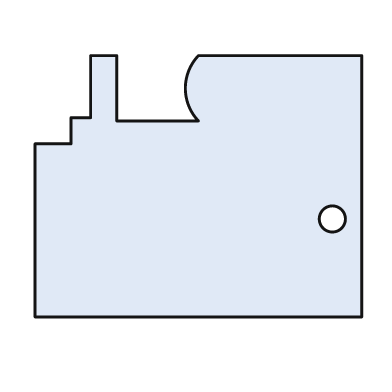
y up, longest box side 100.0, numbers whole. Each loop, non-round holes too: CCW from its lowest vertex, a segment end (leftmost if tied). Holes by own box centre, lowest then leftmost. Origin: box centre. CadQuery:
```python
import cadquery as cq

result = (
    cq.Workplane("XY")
    .moveTo(-50.0, -40.0)
    .lineTo(50.0, -40.0)
    .lineTo(50.0, 40.0)
    .lineTo(0.0, 40.0)
    .threePointArc((-4.0, 30.0), (0.0, 20.0))
    .lineTo(-25.0, 20.0)
    .lineTo(-25.0, 40.0)
    .lineTo(-33.0, 40.0)
    .lineTo(-33.0, 21.0)
    .lineTo(-39.0, 21.0)
    .lineTo(-39.0, 13.0)
    .lineTo(-50.0, 13.0)
    .close()
    .moveTo(41.0, -10.0)
    .circle(4.0)
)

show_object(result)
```